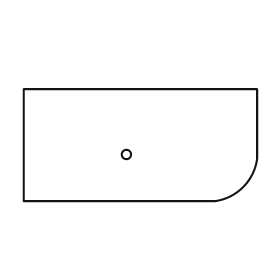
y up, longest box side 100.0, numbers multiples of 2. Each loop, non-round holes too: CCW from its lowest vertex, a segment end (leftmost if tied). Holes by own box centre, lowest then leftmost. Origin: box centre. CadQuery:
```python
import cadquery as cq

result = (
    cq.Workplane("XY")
    .moveTo(-50.0, -24.0)
    .lineTo(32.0, -24.0)
    .threePointArc((44.0, -18.0), (50.0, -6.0))
    .lineTo(50.0, 24.0)
    .lineTo(-50.0, 24.0)
    .close()
    .moveTo(-6.0, -4.0)
    .circle(2.0)
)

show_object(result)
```